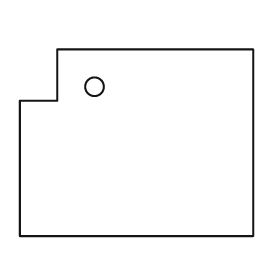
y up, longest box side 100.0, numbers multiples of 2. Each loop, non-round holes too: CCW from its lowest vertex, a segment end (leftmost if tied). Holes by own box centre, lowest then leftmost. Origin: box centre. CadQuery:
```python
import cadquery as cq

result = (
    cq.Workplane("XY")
    .moveTo(-50.0, -40.0)
    .lineTo(50.0, -40.0)
    .lineTo(50.0, 40.0)
    .lineTo(-34.0, 40.0)
    .lineTo(-34.0, 18.0)
    .lineTo(-50.0, 18.0)
    .close()
    .moveTo(-18.0, 24.0)
    .circle(4.0)
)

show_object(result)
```